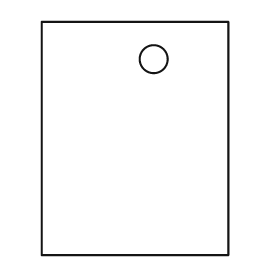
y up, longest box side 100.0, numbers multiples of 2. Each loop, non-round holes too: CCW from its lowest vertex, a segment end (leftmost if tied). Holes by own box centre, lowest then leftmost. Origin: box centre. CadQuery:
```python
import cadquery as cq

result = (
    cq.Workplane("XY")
    .moveTo(-40.0, -50.0)
    .lineTo(40.0, -50.0)
    .lineTo(40.0, 50.0)
    .lineTo(-40.0, 50.0)
    .close()
    .moveTo(8.0, 34.0)
    .circle(6.0)
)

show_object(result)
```